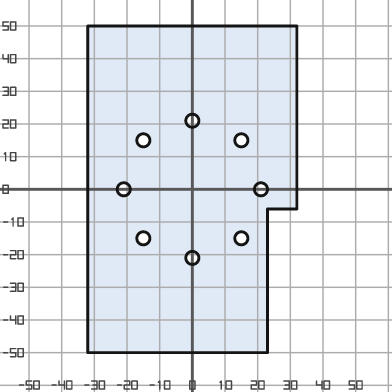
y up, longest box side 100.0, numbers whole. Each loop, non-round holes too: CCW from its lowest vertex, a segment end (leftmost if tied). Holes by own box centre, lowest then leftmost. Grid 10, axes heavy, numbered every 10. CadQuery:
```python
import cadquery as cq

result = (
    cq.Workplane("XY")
    .moveTo(-32.0, -50.0)
    .lineTo(23.0, -50.0)
    .lineTo(23.0, -6.0)
    .lineTo(32.0, -6.0)
    .lineTo(32.0, 50.0)
    .lineTo(-32.0, 50.0)
    .close()
    .moveTo(0.0, -21.0)
    .circle(2.0)
    .moveTo(-15.0, -15.0)
    .circle(2.0)
    .moveTo(15.0, -15.0)
    .circle(2.0)
    .moveTo(-21.0, 0.0)
    .circle(2.0)
    .moveTo(21.0, 0.0)
    .circle(2.0)
    .moveTo(-15.0, 15.0)
    .circle(2.0)
    .moveTo(15.0, 15.0)
    .circle(2.0)
    .moveTo(0.0, 21.0)
    .circle(2.0)
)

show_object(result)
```